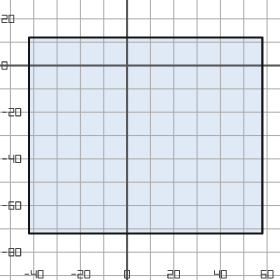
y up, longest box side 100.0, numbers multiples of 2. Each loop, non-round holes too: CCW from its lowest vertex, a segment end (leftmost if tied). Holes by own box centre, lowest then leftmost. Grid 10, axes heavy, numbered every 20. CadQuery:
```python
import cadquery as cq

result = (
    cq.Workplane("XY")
    .moveTo(-42.0, -72.0)
    .lineTo(58.0, -72.0)
    .lineTo(58.0, 12.0)
    .lineTo(-42.0, 12.0)
    .close()
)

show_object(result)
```